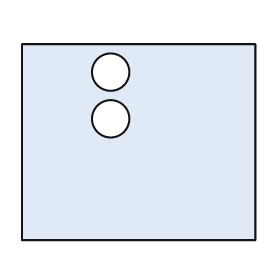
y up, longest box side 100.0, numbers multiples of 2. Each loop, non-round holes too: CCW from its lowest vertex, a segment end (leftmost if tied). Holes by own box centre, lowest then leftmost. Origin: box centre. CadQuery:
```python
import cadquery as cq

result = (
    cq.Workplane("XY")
    .moveTo(-50.0, -42.0)
    .lineTo(50.0, -42.0)
    .lineTo(50.0, 42.0)
    .lineTo(-50.0, 42.0)
    .close()
    .moveTo(-12.0, 10.0)
    .circle(8.0)
    .moveTo(-12.0, 30.0)
    .circle(8.0)
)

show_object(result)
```